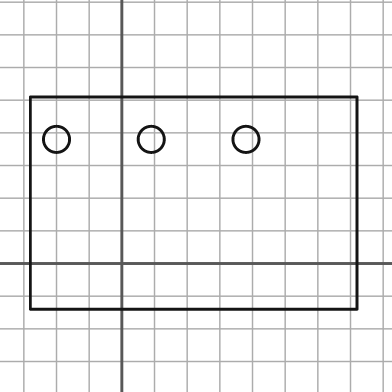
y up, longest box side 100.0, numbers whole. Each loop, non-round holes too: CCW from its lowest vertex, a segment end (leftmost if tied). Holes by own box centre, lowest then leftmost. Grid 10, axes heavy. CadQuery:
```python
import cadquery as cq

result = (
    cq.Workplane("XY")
    .moveTo(-28.0, -14.0)
    .lineTo(72.0, -14.0)
    .lineTo(72.0, 51.0)
    .lineTo(-28.0, 51.0)
    .close()
    .moveTo(-20.0, 38.0)
    .circle(4.0)
    .moveTo(9.0, 38.0)
    .circle(4.0)
    .moveTo(38.0, 38.0)
    .circle(4.0)
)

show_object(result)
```